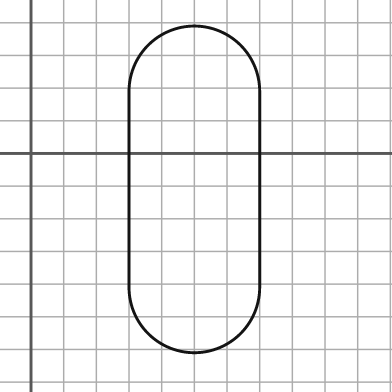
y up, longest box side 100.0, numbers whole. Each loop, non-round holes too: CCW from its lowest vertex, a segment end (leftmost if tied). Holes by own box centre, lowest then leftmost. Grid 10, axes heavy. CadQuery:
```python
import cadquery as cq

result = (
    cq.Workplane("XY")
    .moveTo(30.0, -41.0)
    .threePointArc((50.0, -61.0), (70.0, -41.0))
    .lineTo(70.0, 19.0)
    .threePointArc((50.0, 39.0), (30.0, 19.0))
    .close()
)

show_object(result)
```